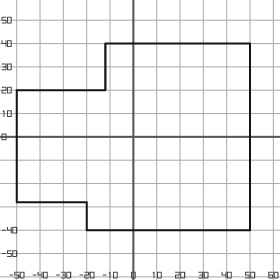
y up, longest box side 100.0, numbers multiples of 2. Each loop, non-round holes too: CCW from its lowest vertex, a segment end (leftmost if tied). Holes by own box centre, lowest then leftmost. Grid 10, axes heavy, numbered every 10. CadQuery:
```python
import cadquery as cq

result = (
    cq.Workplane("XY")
    .moveTo(-20.0, -40.0)
    .lineTo(50.0, -40.0)
    .lineTo(50.0, 40.0)
    .lineTo(-12.0, 40.0)
    .lineTo(-12.0, 20.0)
    .lineTo(-50.0, 20.0)
    .lineTo(-50.0, -28.0)
    .lineTo(-20.0, -28.0)
    .close()
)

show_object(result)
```